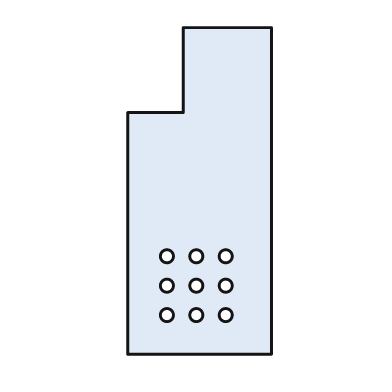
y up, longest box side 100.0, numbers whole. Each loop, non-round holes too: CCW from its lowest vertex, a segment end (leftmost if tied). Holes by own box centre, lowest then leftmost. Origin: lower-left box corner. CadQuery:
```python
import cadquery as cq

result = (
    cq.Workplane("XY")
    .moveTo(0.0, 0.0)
    .lineTo(44.0, 0.0)
    .lineTo(44.0, 100.0)
    .lineTo(17.0, 100.0)
    .lineTo(17.0, 74.0)
    .lineTo(0.0, 74.0)
    .close()
    .moveTo(12.0, 12.0)
    .circle(2.0)
    .moveTo(21.0, 12.0)
    .circle(2.0)
    .moveTo(30.0, 12.0)
    .circle(2.0)
    .moveTo(12.0, 21.0)
    .circle(2.0)
    .moveTo(21.0, 21.0)
    .circle(2.0)
    .moveTo(30.0, 21.0)
    .circle(2.0)
    .moveTo(12.0, 30.0)
    .circle(2.0)
    .moveTo(21.0, 30.0)
    .circle(2.0)
    .moveTo(30.0, 30.0)
    .circle(2.0)
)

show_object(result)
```